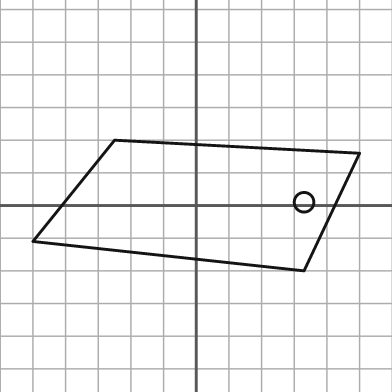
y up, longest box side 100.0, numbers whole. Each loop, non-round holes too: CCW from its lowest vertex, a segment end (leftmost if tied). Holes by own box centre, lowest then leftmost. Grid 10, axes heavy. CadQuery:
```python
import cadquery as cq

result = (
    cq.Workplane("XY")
    .moveTo(33.0, -20.0)
    .lineTo(50.0, 16.0)
    .lineTo(-25.0, 20.0)
    .lineTo(-50.0, -11.0)
    .close()
    .moveTo(33.0, 1.0)
    .circle(3.0)
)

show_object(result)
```